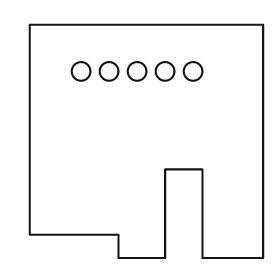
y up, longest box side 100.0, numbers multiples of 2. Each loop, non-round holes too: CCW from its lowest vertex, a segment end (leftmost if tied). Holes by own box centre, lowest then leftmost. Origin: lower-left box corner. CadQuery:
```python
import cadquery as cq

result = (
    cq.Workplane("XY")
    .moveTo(38.0, 0.0)
    .lineTo(58.0, 0.0)
    .lineTo(58.0, 38.0)
    .lineTo(74.0, 38.0)
    .lineTo(74.0, 0.0)
    .lineTo(100.0, 0.0)
    .lineTo(100.0, 100.0)
    .lineTo(0.0, 100.0)
    .lineTo(0.0, 10.0)
    .lineTo(38.0, 10.0)
    .close()
    .moveTo(22.0, 80.0)
    .circle(4.0)
    .moveTo(34.0, 80.0)
    .circle(4.0)
    .moveTo(46.0, 80.0)
    .circle(4.0)
    .moveTo(58.0, 80.0)
    .circle(4.0)
    .moveTo(70.0, 80.0)
    .circle(4.0)
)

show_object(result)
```